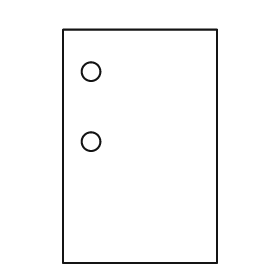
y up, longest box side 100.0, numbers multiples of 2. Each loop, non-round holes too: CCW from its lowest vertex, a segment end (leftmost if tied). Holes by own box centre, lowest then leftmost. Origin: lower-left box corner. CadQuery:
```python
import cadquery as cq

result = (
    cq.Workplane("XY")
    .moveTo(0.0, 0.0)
    .lineTo(66.0, 0.0)
    .lineTo(66.0, 100.0)
    .lineTo(0.0, 100.0)
    .close()
    .moveTo(12.0, 52.0)
    .circle(4.0)
    .moveTo(12.0, 82.0)
    .circle(4.0)
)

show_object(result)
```